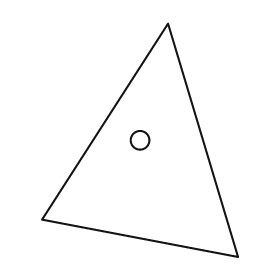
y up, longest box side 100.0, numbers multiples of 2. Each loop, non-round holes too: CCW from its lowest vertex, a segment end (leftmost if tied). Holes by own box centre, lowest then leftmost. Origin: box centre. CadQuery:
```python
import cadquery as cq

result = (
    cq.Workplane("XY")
    .moveTo(42.0, -50.0)
    .lineTo(12.0, 50.0)
    .lineTo(-42.0, -34.0)
    .close()
    .moveTo(0.0, 0.0)
    .circle(4.0)
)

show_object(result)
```